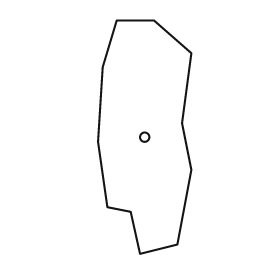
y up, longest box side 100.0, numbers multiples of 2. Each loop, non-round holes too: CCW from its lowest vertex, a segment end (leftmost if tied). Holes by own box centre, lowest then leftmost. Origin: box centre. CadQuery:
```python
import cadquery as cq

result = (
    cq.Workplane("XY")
    .moveTo(-2.0, -50.0)
    .lineTo(14.0, -46.0)
    .lineTo(20.0, -14.0)
    .lineTo(16.0, 6.0)
    .lineTo(20.0, 36.0)
    .lineTo(4.0, 50.0)
    .lineTo(-12.0, 50.0)
    .lineTo(-18.0, 30.0)
    .lineTo(-20.0, -2.0)
    .lineTo(-16.0, -30.0)
    .lineTo(-6.0, -32.0)
    .close()
    .moveTo(0.0, 0.0)
    .circle(2.0)
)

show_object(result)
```